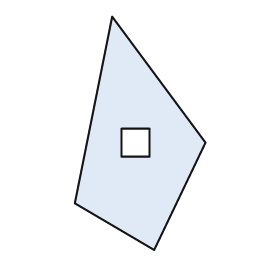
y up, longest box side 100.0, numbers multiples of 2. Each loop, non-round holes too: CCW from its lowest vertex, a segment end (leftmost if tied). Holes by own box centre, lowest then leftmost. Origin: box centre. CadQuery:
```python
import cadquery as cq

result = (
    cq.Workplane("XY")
    .moveTo(6.0, -50.0)
    .lineTo(28.0, -4.0)
    .lineTo(-12.0, 50.0)
    .lineTo(-28.0, -30.0)
    .close()
    .moveTo(-8.0, -10.0)
    .lineTo(4.0, -10.0)
    .lineTo(4.0, 2.0)
    .lineTo(-8.0, 2.0)
    .close()
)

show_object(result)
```